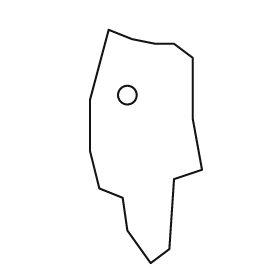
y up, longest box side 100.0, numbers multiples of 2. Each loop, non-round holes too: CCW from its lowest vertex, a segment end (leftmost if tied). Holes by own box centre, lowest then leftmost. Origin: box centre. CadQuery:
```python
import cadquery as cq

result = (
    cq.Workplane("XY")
    .moveTo(2.0, -50.0)
    .lineTo(10.0, -44.0)
    .lineTo(12.0, -14.0)
    .lineTo(24.0, -10.0)
    .lineTo(20.0, 12.0)
    .lineTo(20.0, 38.0)
    .lineTo(12.0, 44.0)
    .lineTo(4.0, 44.0)
    .lineTo(-6.0, 46.0)
    .lineTo(-16.0, 50.0)
    .lineTo(-24.0, 20.0)
    .lineTo(-24.0, -2.0)
    .lineTo(-20.0, -18.0)
    .lineTo(-10.0, -22.0)
    .lineTo(-8.0, -36.0)
    .close()
    .moveTo(-8.0, 22.0)
    .circle(4.0)
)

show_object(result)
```